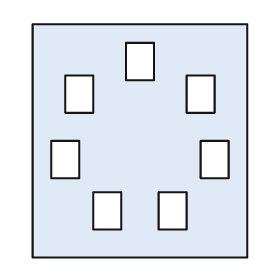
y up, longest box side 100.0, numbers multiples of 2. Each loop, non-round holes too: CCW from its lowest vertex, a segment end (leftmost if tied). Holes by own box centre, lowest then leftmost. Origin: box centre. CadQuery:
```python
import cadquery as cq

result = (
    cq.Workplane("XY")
    .moveTo(-46.0, -50.0)
    .lineTo(46.0, -50.0)
    .lineTo(46.0, 50.0)
    .lineTo(-46.0, 50.0)
    .close()
    .moveTo(-20.0, -38.0)
    .lineTo(-8.0, -38.0)
    .lineTo(-8.0, -22.0)
    .lineTo(-20.0, -22.0)
    .close()
    .moveTo(8.0, -38.0)
    .lineTo(20.0, -38.0)
    .lineTo(20.0, -22.0)
    .lineTo(8.0, -22.0)
    .close()
    .moveTo(-38.0, -16.0)
    .lineTo(-26.0, -16.0)
    .lineTo(-26.0, 0.0)
    .lineTo(-38.0, 0.0)
    .close()
    .moveTo(26.0, -16.0)
    .lineTo(38.0, -16.0)
    .lineTo(38.0, 0.0)
    .lineTo(26.0, 0.0)
    .close()
    .moveTo(-32.0, 12.0)
    .lineTo(-20.0, 12.0)
    .lineTo(-20.0, 28.0)
    .lineTo(-32.0, 28.0)
    .close()
    .moveTo(20.0, 12.0)
    .lineTo(32.0, 12.0)
    .lineTo(32.0, 28.0)
    .lineTo(20.0, 28.0)
    .close()
    .moveTo(-6.0, 26.0)
    .lineTo(6.0, 26.0)
    .lineTo(6.0, 42.0)
    .lineTo(-6.0, 42.0)
    .close()
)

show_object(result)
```